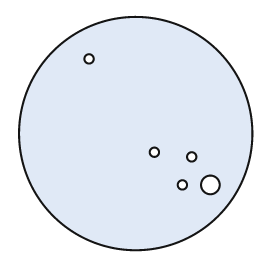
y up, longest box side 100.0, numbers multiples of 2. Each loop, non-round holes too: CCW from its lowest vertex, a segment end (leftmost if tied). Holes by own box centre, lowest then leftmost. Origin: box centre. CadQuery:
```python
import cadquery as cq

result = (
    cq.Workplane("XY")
    .moveTo(0.0, 0.0)
    .circle(50.0)
    .moveTo(20.0, -22.0)
    .circle(2.0)
    .moveTo(32.0, -22.0)
    .circle(4.0)
    .moveTo(24.0, -10.0)
    .circle(2.0)
    .moveTo(8.0, -8.0)
    .circle(2.0)
    .moveTo(-20.0, 32.0)
    .circle(2.0)
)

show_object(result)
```